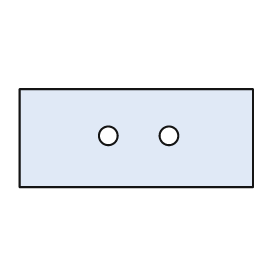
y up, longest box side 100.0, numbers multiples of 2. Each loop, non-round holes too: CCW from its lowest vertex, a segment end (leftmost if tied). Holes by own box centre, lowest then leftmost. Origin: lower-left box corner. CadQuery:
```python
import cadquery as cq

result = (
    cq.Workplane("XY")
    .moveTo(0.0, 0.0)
    .lineTo(100.0, 0.0)
    .lineTo(100.0, 42.0)
    .lineTo(0.0, 42.0)
    .close()
    .moveTo(38.0, 22.0)
    .circle(4.0)
    .moveTo(64.0, 22.0)
    .circle(4.0)
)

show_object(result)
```